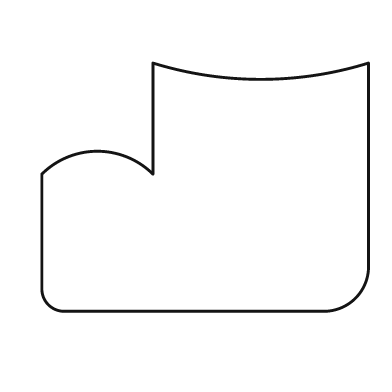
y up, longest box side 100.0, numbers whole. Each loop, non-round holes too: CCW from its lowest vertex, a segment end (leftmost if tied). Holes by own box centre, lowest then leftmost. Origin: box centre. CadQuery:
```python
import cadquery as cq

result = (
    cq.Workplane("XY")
    .moveTo(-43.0, -38.0)
    .lineTo(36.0, -38.0)
    .threePointArc((46.0, -34.0), (50.0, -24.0))
    .lineTo(50.0, 38.0)
    .threePointArc((17.0, 33.0), (-16.0, 38.0))
    .lineTo(-16.0, 4.0)
    .threePointArc((-33.0, 11.0), (-50.0, 4.0))
    .lineTo(-50.0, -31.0)
    .threePointArc((-48.0, -36.0), (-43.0, -38.0))
    .close()
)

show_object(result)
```